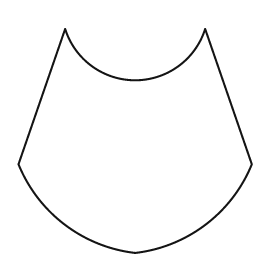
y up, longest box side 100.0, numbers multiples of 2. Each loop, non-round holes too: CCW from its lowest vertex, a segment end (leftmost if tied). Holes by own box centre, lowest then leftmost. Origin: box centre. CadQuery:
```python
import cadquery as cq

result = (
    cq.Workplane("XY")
    .moveTo(0.0, -48.0)
    .threePointArc((30.0, -36.0), (50.0, -10.0))
    .lineTo(30.0, 48.0)
    .threePointArc((0.0, 26.0), (-30.0, 48.0))
    .lineTo(-50.0, -10.0)
    .threePointArc((-30.0, -36.0), (0.0, -48.0))
    .close()
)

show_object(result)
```